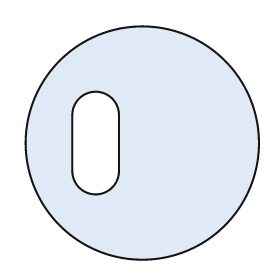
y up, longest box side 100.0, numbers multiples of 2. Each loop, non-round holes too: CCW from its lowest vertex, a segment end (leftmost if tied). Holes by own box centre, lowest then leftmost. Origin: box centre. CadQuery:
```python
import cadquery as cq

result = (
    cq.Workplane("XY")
    .moveTo(0.0, 0.0)
    .circle(50.0)
    .moveTo(-30.0, -12.0)
    .threePointArc((-20.0, -22.0), (-10.0, -12.0))
    .lineTo(-10.0, 12.0)
    .threePointArc((-20.0, 22.0), (-30.0, 12.0))
    .close()
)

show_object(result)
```